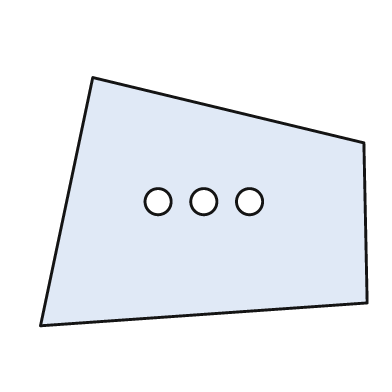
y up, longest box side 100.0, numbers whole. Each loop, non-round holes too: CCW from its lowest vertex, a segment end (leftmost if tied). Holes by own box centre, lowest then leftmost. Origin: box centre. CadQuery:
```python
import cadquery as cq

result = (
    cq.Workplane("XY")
    .moveTo(-50.0, -38.0)
    .lineTo(50.0, -31.0)
    .lineTo(49.0, 18.0)
    .lineTo(-34.0, 38.0)
    .close()
    .moveTo(-14.0, 0.0)
    .circle(4.0)
    .moveTo(0.0, 0.0)
    .circle(4.0)
    .moveTo(14.0, 0.0)
    .circle(4.0)
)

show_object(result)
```